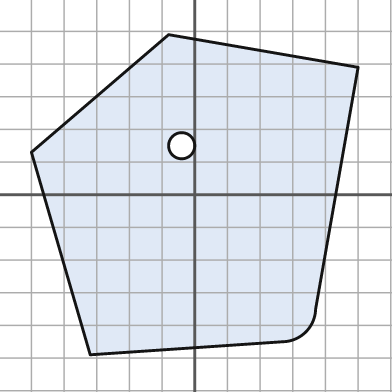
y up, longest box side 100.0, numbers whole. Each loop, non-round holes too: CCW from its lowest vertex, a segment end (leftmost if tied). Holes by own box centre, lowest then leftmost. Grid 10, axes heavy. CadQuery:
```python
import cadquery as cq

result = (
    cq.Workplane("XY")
    .moveTo(-32.0, -49.0)
    .lineTo(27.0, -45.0)
    .threePointArc((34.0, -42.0), (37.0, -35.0))
    .lineTo(50.0, 39.0)
    .lineTo(-8.0, 49.0)
    .lineTo(-50.0, 13.0)
    .close()
    .moveTo(-4.0, 15.0)
    .circle(4.0)
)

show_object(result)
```